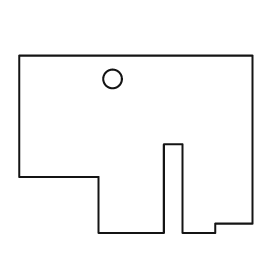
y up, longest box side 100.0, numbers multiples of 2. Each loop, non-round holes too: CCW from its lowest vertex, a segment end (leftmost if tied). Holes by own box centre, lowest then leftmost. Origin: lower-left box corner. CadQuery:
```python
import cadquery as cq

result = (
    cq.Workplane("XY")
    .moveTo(34.0, 0.0)
    .lineTo(62.0, 0.0)
    .lineTo(62.0, 38.0)
    .lineTo(70.0, 38.0)
    .lineTo(70.0, 0.0)
    .lineTo(84.0, 0.0)
    .lineTo(84.0, 4.0)
    .lineTo(100.0, 4.0)
    .lineTo(100.0, 76.0)
    .lineTo(0.0, 76.0)
    .lineTo(0.0, 24.0)
    .lineTo(34.0, 24.0)
    .close()
    .moveTo(40.0, 66.0)
    .circle(4.0)
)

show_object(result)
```